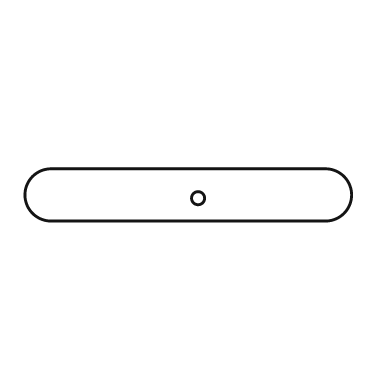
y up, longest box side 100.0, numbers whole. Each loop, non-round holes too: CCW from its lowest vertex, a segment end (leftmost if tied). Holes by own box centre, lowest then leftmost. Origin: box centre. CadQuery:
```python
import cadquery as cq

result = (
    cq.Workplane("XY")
    .moveTo(-42.0, -8.0)
    .lineTo(42.0, -8.0)
    .threePointArc((50.0, 0.0), (42.0, 8.0))
    .lineTo(-42.0, 8.0)
    .threePointArc((-50.0, 0.0), (-42.0, -8.0))
    .close()
    .moveTo(3.0, -1.0)
    .circle(2.0)
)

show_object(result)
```